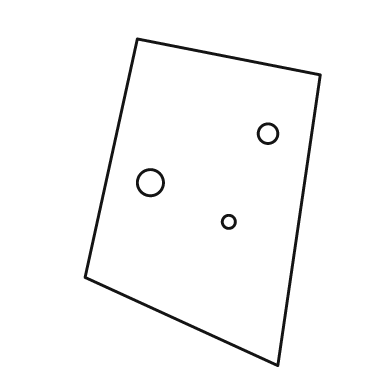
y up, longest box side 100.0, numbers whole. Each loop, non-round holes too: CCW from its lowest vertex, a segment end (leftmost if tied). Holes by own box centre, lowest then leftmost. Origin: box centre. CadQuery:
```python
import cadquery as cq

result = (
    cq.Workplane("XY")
    .moveTo(23.0, -50.0)
    .lineTo(36.0, 39.0)
    .lineTo(-20.0, 50.0)
    .lineTo(-36.0, -23.0)
    .close()
    .moveTo(8.0, -6.0)
    .circle(2.0)
    .moveTo(-16.0, 6.0)
    .circle(4.0)
    .moveTo(20.0, 21.0)
    .circle(3.0)
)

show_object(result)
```